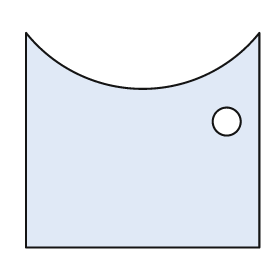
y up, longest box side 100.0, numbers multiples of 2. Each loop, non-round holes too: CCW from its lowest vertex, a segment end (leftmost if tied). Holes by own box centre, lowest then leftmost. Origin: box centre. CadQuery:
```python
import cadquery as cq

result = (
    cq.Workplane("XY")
    .moveTo(-50.0, -46.0)
    .lineTo(50.0, -46.0)
    .lineTo(50.0, 46.0)
    .threePointArc((0.0, 22.0), (-50.0, 46.0))
    .close()
    .moveTo(36.0, 8.0)
    .circle(6.0)
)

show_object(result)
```